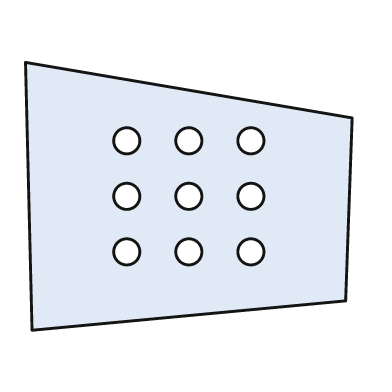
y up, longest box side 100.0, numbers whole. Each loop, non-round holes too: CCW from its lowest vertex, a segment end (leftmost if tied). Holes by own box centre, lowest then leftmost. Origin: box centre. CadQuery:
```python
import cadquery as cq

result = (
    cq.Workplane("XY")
    .moveTo(-48.0, -41.0)
    .lineTo(48.0, -32.0)
    .lineTo(50.0, 24.0)
    .lineTo(-50.0, 41.0)
    .close()
    .moveTo(-19.0, -17.0)
    .circle(4.0)
    .moveTo(0.0, -17.0)
    .circle(4.0)
    .moveTo(19.0, -17.0)
    .circle(4.0)
    .moveTo(-19.0, 0.0)
    .circle(4.0)
    .moveTo(0.0, 0.0)
    .circle(4.0)
    .moveTo(19.0, 0.0)
    .circle(4.0)
    .moveTo(-19.0, 17.0)
    .circle(4.0)
    .moveTo(0.0, 17.0)
    .circle(4.0)
    .moveTo(19.0, 17.0)
    .circle(4.0)
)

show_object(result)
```